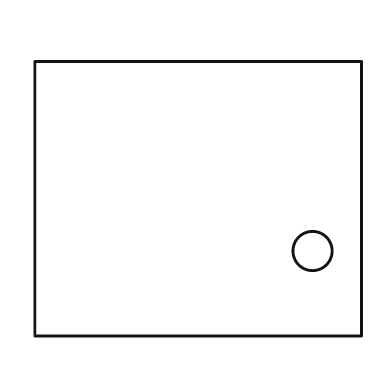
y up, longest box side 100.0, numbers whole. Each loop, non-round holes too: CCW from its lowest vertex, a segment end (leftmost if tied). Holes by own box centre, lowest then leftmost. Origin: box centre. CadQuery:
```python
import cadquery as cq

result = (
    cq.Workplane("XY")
    .moveTo(-50.0, -42.0)
    .lineTo(50.0, -42.0)
    .lineTo(50.0, 42.0)
    .lineTo(-50.0, 42.0)
    .close()
    .moveTo(35.0, -16.0)
    .circle(6.0)
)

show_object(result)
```